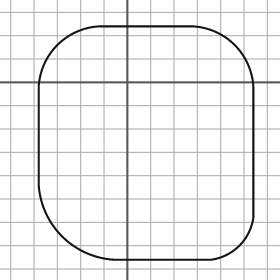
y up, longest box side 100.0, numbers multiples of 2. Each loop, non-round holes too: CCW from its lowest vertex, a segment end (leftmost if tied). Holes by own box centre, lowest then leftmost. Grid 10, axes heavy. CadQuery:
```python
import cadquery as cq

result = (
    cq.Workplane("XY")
    .moveTo(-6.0, -76.0)
    .lineTo(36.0, -76.0)
    .threePointArc((48.0, -70.0), (54.0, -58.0))
    .lineTo(54.0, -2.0)
    .threePointArc((46.0, 16.0), (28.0, 24.0))
    .lineTo(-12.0, 24.0)
    .threePointArc((-30.0, 16.0), (-38.0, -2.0))
    .lineTo(-38.0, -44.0)
    .threePointArc((-28.0, -66.0), (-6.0, -76.0))
    .close()
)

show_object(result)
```